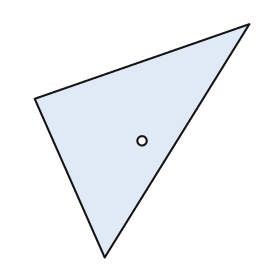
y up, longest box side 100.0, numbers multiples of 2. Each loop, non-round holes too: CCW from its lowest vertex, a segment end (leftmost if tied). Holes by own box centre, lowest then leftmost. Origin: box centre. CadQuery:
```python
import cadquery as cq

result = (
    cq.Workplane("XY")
    .moveTo(-16.0, -50.0)
    .lineTo(46.0, 50.0)
    .lineTo(-46.0, 18.0)
    .close()
    .moveTo(0.0, 0.0)
    .circle(2.0)
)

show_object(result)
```